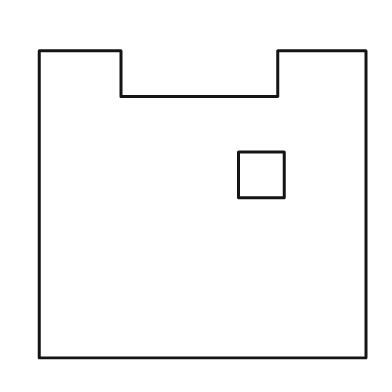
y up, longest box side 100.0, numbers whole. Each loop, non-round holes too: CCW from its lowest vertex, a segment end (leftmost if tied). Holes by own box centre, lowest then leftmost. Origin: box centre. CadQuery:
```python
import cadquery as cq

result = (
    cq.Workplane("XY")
    .moveTo(-50.0, -47.0)
    .lineTo(50.0, -47.0)
    .lineTo(50.0, 47.0)
    .lineTo(23.0, 47.0)
    .lineTo(23.0, 33.0)
    .lineTo(-25.0, 33.0)
    .lineTo(-25.0, 47.0)
    .lineTo(-50.0, 47.0)
    .close()
    .moveTo(11.0, 2.0)
    .lineTo(25.0, 2.0)
    .lineTo(25.0, 16.0)
    .lineTo(11.0, 16.0)
    .close()
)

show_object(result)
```